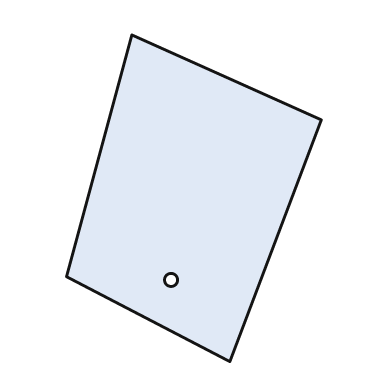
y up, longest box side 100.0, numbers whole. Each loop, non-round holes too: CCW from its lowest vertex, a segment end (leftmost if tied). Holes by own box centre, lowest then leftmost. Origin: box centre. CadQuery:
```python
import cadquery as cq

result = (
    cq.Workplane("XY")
    .moveTo(11.0, -50.0)
    .lineTo(39.0, 24.0)
    .lineTo(-19.0, 50.0)
    .lineTo(-39.0, -24.0)
    .close()
    .moveTo(-7.0, -25.0)
    .circle(2.0)
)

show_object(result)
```